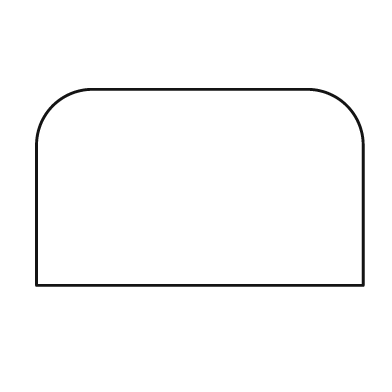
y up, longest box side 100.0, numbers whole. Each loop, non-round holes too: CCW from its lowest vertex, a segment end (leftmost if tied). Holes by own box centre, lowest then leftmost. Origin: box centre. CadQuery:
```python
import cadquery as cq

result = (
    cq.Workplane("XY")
    .moveTo(-50.0, -30.0)
    .lineTo(50.0, -30.0)
    .lineTo(50.0, 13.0)
    .threePointArc((45.0, 25.0), (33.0, 30.0))
    .lineTo(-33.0, 30.0)
    .threePointArc((-45.0, 25.0), (-50.0, 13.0))
    .close()
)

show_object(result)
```